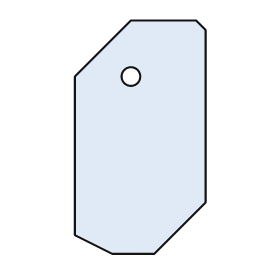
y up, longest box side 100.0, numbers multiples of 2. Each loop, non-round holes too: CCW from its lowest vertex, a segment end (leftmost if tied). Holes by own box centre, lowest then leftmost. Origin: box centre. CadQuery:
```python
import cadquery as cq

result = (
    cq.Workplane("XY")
    .moveTo(-12.0, -50.0)
    .lineTo(6.0, -50.0)
    .lineTo(28.0, -28.0)
    .lineTo(28.0, 46.0)
    .lineTo(24.0, 50.0)
    .lineTo(-4.0, 50.0)
    .lineTo(-28.0, 26.0)
    .lineTo(-28.0, -42.0)
    .close()
    .moveTo(-4.0, 26.0)
    .circle(4.0)
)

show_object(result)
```